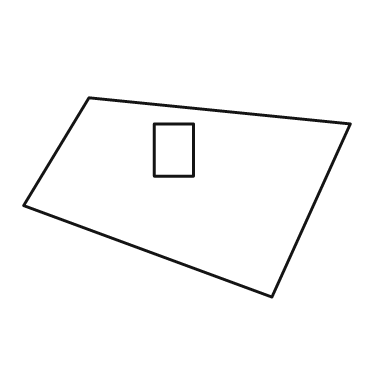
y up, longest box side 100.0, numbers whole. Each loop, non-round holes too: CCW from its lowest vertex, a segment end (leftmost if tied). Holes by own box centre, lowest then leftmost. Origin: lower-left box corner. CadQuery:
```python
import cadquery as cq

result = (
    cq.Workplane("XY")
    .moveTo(76.0, 0.0)
    .lineTo(100.0, 53.0)
    .lineTo(20.0, 61.0)
    .lineTo(0.0, 28.0)
    .close()
    .moveTo(40.0, 37.0)
    .lineTo(52.0, 37.0)
    .lineTo(52.0, 53.0)
    .lineTo(40.0, 53.0)
    .close()
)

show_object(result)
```